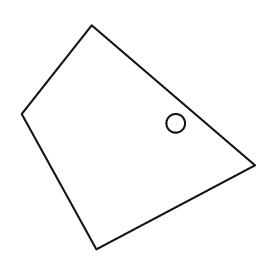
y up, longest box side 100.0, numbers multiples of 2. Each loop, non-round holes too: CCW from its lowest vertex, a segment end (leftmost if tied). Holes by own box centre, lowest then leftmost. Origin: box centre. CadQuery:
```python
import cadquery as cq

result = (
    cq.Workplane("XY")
    .moveTo(-18.0, -48.0)
    .lineTo(50.0, -12.0)
    .lineTo(-20.0, 48.0)
    .lineTo(-50.0, 10.0)
    .close()
    .moveTo(16.0, 6.0)
    .circle(4.0)
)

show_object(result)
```